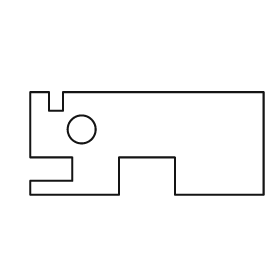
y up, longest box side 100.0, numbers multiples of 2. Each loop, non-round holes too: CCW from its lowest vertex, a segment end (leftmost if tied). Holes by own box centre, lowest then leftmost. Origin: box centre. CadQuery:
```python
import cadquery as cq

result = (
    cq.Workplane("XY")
    .moveTo(-50.0, -22.0)
    .lineTo(-12.0, -22.0)
    .lineTo(-12.0, -6.0)
    .lineTo(12.0, -6.0)
    .lineTo(12.0, -22.0)
    .lineTo(50.0, -22.0)
    .lineTo(50.0, 22.0)
    .lineTo(-36.0, 22.0)
    .lineTo(-36.0, 14.0)
    .lineTo(-42.0, 14.0)
    .lineTo(-42.0, 22.0)
    .lineTo(-50.0, 22.0)
    .lineTo(-50.0, -6.0)
    .lineTo(-32.0, -6.0)
    .lineTo(-32.0, -16.0)
    .lineTo(-50.0, -16.0)
    .close()
    .moveTo(-28.0, 6.0)
    .circle(6.0)
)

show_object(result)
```